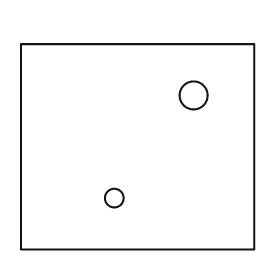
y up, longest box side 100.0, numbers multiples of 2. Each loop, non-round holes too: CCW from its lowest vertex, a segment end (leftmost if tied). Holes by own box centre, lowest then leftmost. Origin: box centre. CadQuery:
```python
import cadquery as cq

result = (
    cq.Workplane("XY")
    .moveTo(-50.0, -44.0)
    .lineTo(50.0, -44.0)
    .lineTo(50.0, 44.0)
    .lineTo(-50.0, 44.0)
    .close()
    .moveTo(-10.0, -22.0)
    .circle(4.0)
    .moveTo(24.0, 22.0)
    .circle(6.0)
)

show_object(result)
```